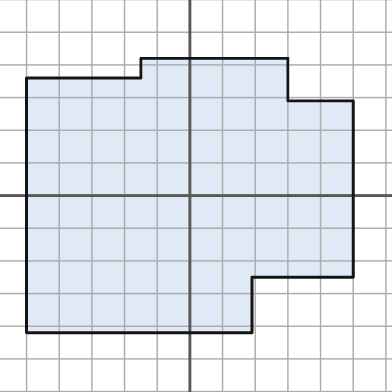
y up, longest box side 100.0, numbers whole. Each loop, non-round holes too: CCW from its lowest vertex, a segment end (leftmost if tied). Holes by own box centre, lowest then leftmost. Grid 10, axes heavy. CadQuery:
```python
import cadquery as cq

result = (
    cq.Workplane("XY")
    .moveTo(-50.0, -42.0)
    .lineTo(19.0, -42.0)
    .lineTo(19.0, -25.0)
    .lineTo(50.0, -25.0)
    .lineTo(50.0, 29.0)
    .lineTo(30.0, 29.0)
    .lineTo(30.0, 42.0)
    .lineTo(-15.0, 42.0)
    .lineTo(-15.0, 36.0)
    .lineTo(-50.0, 36.0)
    .close()
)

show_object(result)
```